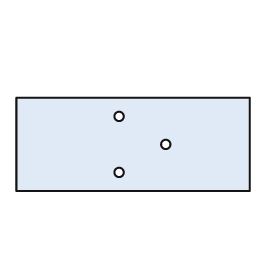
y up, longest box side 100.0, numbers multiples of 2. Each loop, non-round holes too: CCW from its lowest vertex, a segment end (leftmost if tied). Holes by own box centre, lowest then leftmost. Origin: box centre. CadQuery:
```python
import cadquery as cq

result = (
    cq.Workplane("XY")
    .moveTo(-50.0, -20.0)
    .lineTo(50.0, -20.0)
    .lineTo(50.0, 20.0)
    .lineTo(-50.0, 20.0)
    .close()
    .moveTo(-6.0, -12.0)
    .circle(2.0)
    .moveTo(14.0, 0.0)
    .circle(2.0)
    .moveTo(-6.0, 12.0)
    .circle(2.0)
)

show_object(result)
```